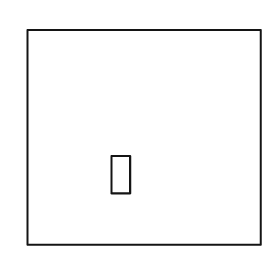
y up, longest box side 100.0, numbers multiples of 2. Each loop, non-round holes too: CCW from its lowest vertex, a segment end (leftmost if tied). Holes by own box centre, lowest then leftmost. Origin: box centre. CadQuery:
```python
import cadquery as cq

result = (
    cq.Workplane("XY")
    .moveTo(-50.0, -46.0)
    .lineTo(50.0, -46.0)
    .lineTo(50.0, 46.0)
    .lineTo(-50.0, 46.0)
    .close()
    .moveTo(-14.0, -24.0)
    .lineTo(-6.0, -24.0)
    .lineTo(-6.0, -8.0)
    .lineTo(-14.0, -8.0)
    .close()
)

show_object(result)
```